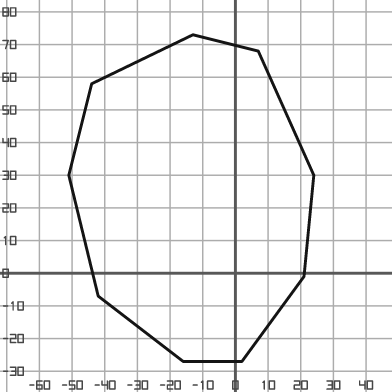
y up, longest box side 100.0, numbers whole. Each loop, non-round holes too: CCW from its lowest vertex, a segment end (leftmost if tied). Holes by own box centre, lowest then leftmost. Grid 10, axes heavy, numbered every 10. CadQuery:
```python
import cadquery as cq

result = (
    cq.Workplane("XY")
    .moveTo(-16.0, -27.0)
    .lineTo(2.0, -27.0)
    .lineTo(21.0, -1.0)
    .lineTo(24.0, 30.0)
    .lineTo(7.0, 68.0)
    .lineTo(-13.0, 73.0)
    .lineTo(-44.0, 58.0)
    .lineTo(-51.0, 30.0)
    .lineTo(-42.0, -7.0)
    .close()
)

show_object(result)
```